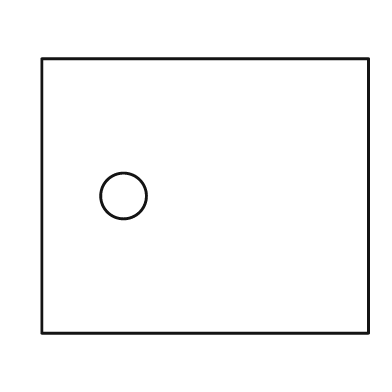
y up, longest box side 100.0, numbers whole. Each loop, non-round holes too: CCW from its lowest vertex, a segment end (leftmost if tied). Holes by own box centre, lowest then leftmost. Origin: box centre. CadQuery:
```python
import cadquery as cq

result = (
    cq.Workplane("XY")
    .moveTo(-50.0, -42.0)
    .lineTo(50.0, -42.0)
    .lineTo(50.0, 42.0)
    .lineTo(-50.0, 42.0)
    .close()
    .moveTo(-25.0, 0.0)
    .circle(7.0)
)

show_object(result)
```